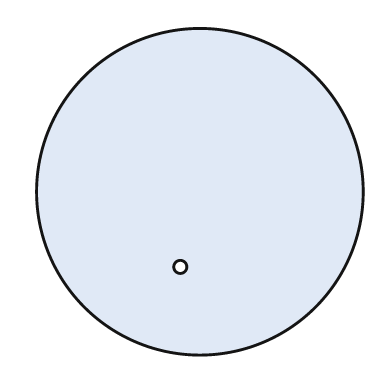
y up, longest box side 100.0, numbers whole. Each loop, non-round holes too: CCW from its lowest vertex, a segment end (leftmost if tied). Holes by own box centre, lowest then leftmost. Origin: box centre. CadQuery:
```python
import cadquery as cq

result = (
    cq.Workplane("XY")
    .moveTo(0.0, 0.0)
    .circle(50.0)
    .moveTo(-6.0, -23.0)
    .circle(2.0)
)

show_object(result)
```